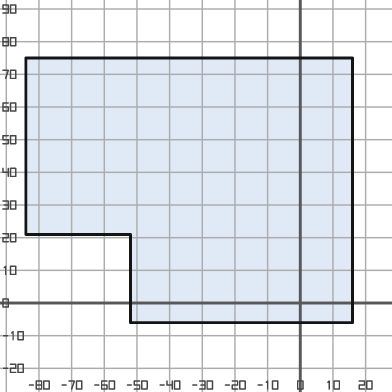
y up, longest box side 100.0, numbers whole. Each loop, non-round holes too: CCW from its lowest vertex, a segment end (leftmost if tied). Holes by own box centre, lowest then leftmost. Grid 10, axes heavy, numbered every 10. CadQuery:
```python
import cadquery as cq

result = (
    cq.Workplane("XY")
    .moveTo(-52.0, -6.0)
    .lineTo(16.0, -6.0)
    .lineTo(16.0, 75.0)
    .lineTo(-84.0, 75.0)
    .lineTo(-84.0, 21.0)
    .lineTo(-52.0, 21.0)
    .close()
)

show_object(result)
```